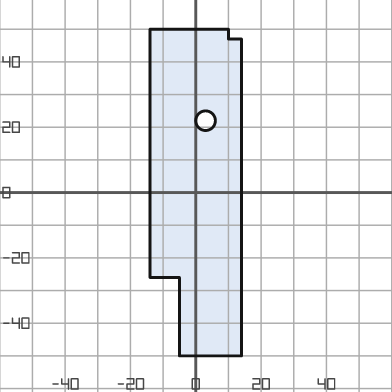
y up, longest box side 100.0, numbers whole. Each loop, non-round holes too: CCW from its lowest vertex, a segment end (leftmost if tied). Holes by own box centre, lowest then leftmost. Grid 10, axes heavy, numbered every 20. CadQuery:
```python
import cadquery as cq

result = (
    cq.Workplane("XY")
    .moveTo(-5.0, -50.0)
    .lineTo(14.0, -50.0)
    .lineTo(14.0, 47.0)
    .lineTo(10.0, 47.0)
    .lineTo(10.0, 50.0)
    .lineTo(-14.0, 50.0)
    .lineTo(-14.0, -26.0)
    .lineTo(-5.0, -26.0)
    .close()
    .moveTo(3.0, 22.0)
    .circle(3.0)
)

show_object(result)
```